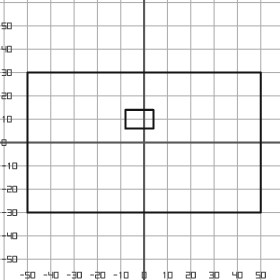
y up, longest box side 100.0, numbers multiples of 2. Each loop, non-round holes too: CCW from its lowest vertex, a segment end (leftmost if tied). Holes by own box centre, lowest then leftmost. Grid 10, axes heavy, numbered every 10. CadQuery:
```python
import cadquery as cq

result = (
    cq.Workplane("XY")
    .moveTo(-50.0, -30.0)
    .lineTo(50.0, -30.0)
    .lineTo(50.0, 30.0)
    .lineTo(-50.0, 30.0)
    .close()
    .moveTo(-8.0, 6.0)
    .lineTo(4.0, 6.0)
    .lineTo(4.0, 14.0)
    .lineTo(-8.0, 14.0)
    .close()
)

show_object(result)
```